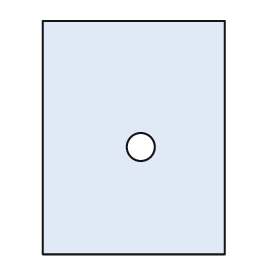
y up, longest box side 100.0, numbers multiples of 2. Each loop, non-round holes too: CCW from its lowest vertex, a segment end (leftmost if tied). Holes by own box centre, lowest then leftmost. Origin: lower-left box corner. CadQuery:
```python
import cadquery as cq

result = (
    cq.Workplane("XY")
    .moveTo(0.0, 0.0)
    .lineTo(78.0, 0.0)
    .lineTo(78.0, 100.0)
    .lineTo(0.0, 100.0)
    .close()
    .moveTo(42.0, 46.0)
    .circle(6.0)
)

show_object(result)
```